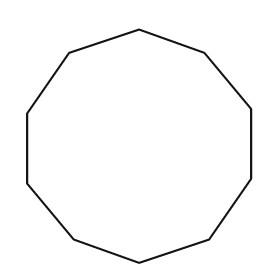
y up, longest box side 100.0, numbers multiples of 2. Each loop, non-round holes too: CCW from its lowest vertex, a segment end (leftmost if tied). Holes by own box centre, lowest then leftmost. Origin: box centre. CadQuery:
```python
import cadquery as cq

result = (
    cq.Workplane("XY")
    .moveTo(0.0, -50.0)
    .lineTo(30.0, -40.0)
    .lineTo(48.0, -14.0)
    .lineTo(48.0, 16.0)
    .lineTo(28.0, 40.0)
    .lineTo(0.0, 50.0)
    .lineTo(-30.0, 40.0)
    .lineTo(-48.0, 14.0)
    .lineTo(-48.0, -16.0)
    .lineTo(-28.0, -40.0)
    .close()
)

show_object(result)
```